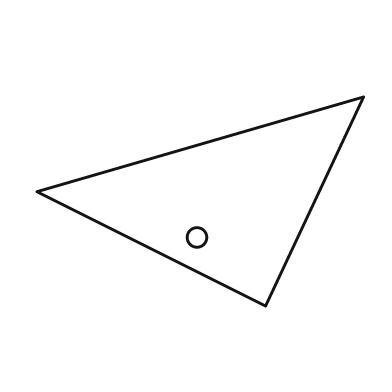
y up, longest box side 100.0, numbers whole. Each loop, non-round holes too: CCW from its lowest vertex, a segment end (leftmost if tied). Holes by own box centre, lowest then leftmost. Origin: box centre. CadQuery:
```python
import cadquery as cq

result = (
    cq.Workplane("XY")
    .moveTo(20.0, -32.0)
    .lineTo(50.0, 32.0)
    .lineTo(-50.0, 3.0)
    .close()
    .moveTo(-1.0, -11.0)
    .circle(3.0)
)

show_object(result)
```